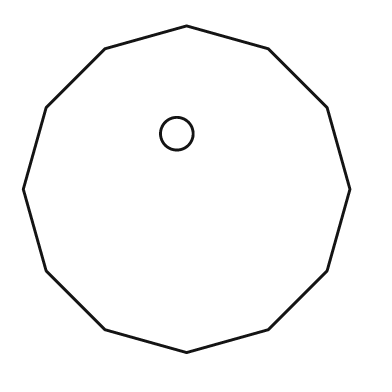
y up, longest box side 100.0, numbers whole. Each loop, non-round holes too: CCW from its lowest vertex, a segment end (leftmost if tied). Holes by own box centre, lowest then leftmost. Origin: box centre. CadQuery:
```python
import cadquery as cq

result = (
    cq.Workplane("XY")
    .moveTo(0.0, -50.0)
    .lineTo(25.0, -43.0)
    .lineTo(43.0, -25.0)
    .lineTo(50.0, 0.0)
    .lineTo(43.0, 25.0)
    .lineTo(25.0, 43.0)
    .lineTo(0.0, 50.0)
    .lineTo(-25.0, 43.0)
    .lineTo(-43.0, 25.0)
    .lineTo(-50.0, 0.0)
    .lineTo(-43.0, -25.0)
    .lineTo(-25.0, -43.0)
    .close()
    .moveTo(-3.0, 17.0)
    .circle(5.0)
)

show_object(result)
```